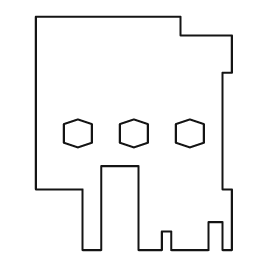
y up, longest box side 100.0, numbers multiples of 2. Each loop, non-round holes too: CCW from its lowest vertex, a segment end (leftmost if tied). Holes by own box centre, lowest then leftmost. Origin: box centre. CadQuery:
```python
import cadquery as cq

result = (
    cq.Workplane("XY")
    .moveTo(-22.0, -50.0)
    .lineTo(-14.0, -50.0)
    .lineTo(-14.0, -14.0)
    .lineTo(2.0, -14.0)
    .lineTo(2.0, -50.0)
    .lineTo(12.0, -50.0)
    .lineTo(12.0, -42.0)
    .lineTo(16.0, -42.0)
    .lineTo(16.0, -50.0)
    .lineTo(32.0, -50.0)
    .lineTo(32.0, -38.0)
    .lineTo(38.0, -38.0)
    .lineTo(38.0, -50.0)
    .lineTo(42.0, -50.0)
    .lineTo(42.0, -24.0)
    .lineTo(38.0, -24.0)
    .lineTo(38.0, 26.0)
    .lineTo(42.0, 26.0)
    .lineTo(42.0, 42.0)
    .lineTo(20.0, 42.0)
    .lineTo(20.0, 50.0)
    .lineTo(-42.0, 50.0)
    .lineTo(-42.0, -24.0)
    .lineTo(-22.0, -24.0)
    .close()
    .moveTo(-24.0, -6.0)
    .lineTo(-18.0, -4.0)
    .lineTo(-18.0, 4.0)
    .lineTo(-24.0, 6.0)
    .lineTo(-30.0, 4.0)
    .lineTo(-30.0, -4.0)
    .close()
    .moveTo(0.0, -6.0)
    .lineTo(6.0, -4.0)
    .lineTo(6.0, 4.0)
    .lineTo(0.0, 6.0)
    .lineTo(-6.0, 4.0)
    .lineTo(-6.0, -4.0)
    .close()
    .moveTo(24.0, -6.0)
    .lineTo(30.0, -4.0)
    .lineTo(30.0, 4.0)
    .lineTo(24.0, 6.0)
    .lineTo(18.0, 4.0)
    .lineTo(18.0, -4.0)
    .close()
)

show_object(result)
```